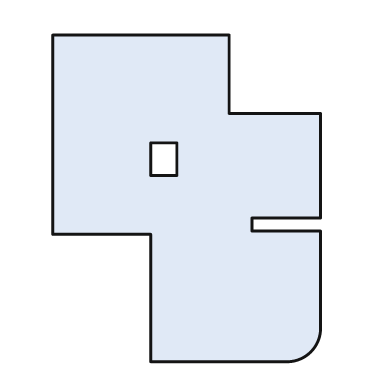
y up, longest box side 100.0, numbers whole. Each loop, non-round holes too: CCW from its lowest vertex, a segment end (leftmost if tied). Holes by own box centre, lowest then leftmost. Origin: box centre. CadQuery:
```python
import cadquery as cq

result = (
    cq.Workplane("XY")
    .moveTo(-11.0, -50.0)
    .lineTo(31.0, -50.0)
    .threePointArc((38.0, -47.0), (41.0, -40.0))
    .lineTo(41.0, -10.0)
    .lineTo(20.0, -10.0)
    .lineTo(20.0, -6.0)
    .lineTo(41.0, -6.0)
    .lineTo(41.0, 26.0)
    .lineTo(13.0, 26.0)
    .lineTo(13.0, 50.0)
    .lineTo(-41.0, 50.0)
    .lineTo(-41.0, -11.0)
    .lineTo(-11.0, -11.0)
    .close()
    .moveTo(-11.0, 7.0)
    .lineTo(-3.0, 7.0)
    .lineTo(-3.0, 17.0)
    .lineTo(-11.0, 17.0)
    .close()
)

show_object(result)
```